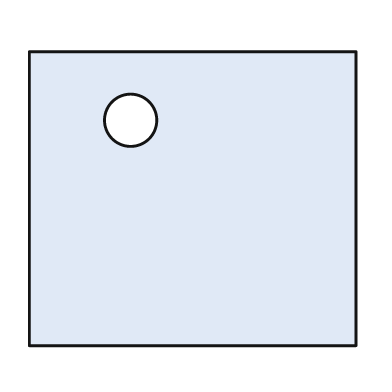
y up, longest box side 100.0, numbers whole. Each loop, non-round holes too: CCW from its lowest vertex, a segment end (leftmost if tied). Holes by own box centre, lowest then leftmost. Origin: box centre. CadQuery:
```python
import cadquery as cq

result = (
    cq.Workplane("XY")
    .moveTo(-50.0, -45.0)
    .lineTo(50.0, -45.0)
    .lineTo(50.0, 45.0)
    .lineTo(-50.0, 45.0)
    .close()
    .moveTo(-19.0, 24.0)
    .circle(8.0)
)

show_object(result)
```